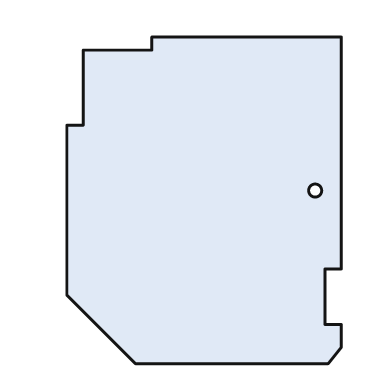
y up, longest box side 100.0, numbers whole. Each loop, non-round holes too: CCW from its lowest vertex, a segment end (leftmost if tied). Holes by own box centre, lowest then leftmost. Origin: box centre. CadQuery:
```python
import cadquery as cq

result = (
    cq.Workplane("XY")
    .moveTo(-21.0, -50.0)
    .lineTo(38.0, -50.0)
    .lineTo(42.0, -45.0)
    .lineTo(42.0, -38.0)
    .lineTo(37.0, -38.0)
    .lineTo(37.0, -21.0)
    .lineTo(42.0, -21.0)
    .lineTo(42.0, 50.0)
    .lineTo(-16.0, 50.0)
    .lineTo(-16.0, 46.0)
    .lineTo(-37.0, 46.0)
    .lineTo(-37.0, 23.0)
    .lineTo(-42.0, 23.0)
    .lineTo(-42.0, -29.0)
    .close()
    .moveTo(34.0, 3.0)
    .circle(2.0)
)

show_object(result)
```